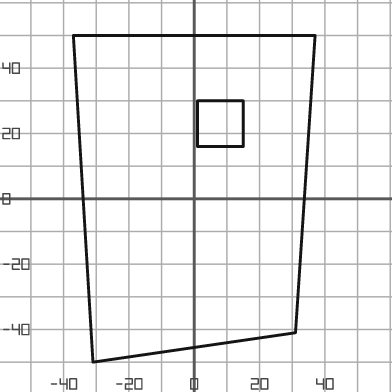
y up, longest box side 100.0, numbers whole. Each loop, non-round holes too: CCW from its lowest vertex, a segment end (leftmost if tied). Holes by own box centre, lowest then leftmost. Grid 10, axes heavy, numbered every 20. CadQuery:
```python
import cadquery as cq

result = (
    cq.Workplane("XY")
    .moveTo(-31.0, -50.0)
    .lineTo(31.0, -41.0)
    .lineTo(37.0, 50.0)
    .lineTo(-37.0, 50.0)
    .close()
    .moveTo(1.0, 16.0)
    .lineTo(15.0, 16.0)
    .lineTo(15.0, 30.0)
    .lineTo(1.0, 30.0)
    .close()
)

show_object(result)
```